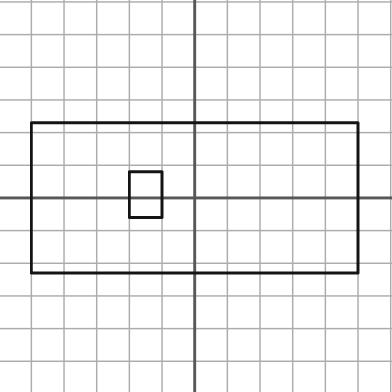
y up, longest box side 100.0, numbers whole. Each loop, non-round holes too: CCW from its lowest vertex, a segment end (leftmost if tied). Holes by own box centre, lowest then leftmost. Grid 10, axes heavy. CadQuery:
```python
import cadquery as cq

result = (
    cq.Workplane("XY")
    .moveTo(-50.0, -23.0)
    .lineTo(50.0, -23.0)
    .lineTo(50.0, 23.0)
    .lineTo(-50.0, 23.0)
    .close()
    .moveTo(-20.0, -6.0)
    .lineTo(-10.0, -6.0)
    .lineTo(-10.0, 8.0)
    .lineTo(-20.0, 8.0)
    .close()
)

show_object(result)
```